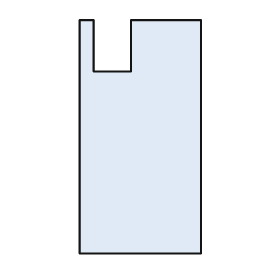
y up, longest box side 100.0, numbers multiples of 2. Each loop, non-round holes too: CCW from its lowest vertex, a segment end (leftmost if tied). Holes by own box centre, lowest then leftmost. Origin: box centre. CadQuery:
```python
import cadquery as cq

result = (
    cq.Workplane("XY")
    .moveTo(-26.0, -50.0)
    .lineTo(26.0, -50.0)
    .lineTo(26.0, 50.0)
    .lineTo(-4.0, 50.0)
    .lineTo(-4.0, 28.0)
    .lineTo(-20.0, 28.0)
    .lineTo(-20.0, 50.0)
    .lineTo(-26.0, 50.0)
    .close()
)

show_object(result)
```